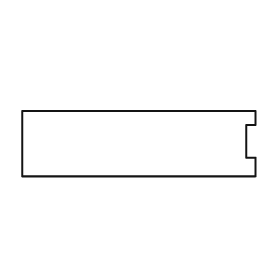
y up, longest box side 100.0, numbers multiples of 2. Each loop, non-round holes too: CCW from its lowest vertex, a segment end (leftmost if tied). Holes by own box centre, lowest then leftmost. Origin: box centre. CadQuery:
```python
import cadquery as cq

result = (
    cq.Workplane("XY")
    .moveTo(-50.0, -14.0)
    .lineTo(50.0, -14.0)
    .lineTo(50.0, -6.0)
    .lineTo(46.0, -6.0)
    .lineTo(46.0, 8.0)
    .lineTo(50.0, 8.0)
    .lineTo(50.0, 14.0)
    .lineTo(-50.0, 14.0)
    .close()
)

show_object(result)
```